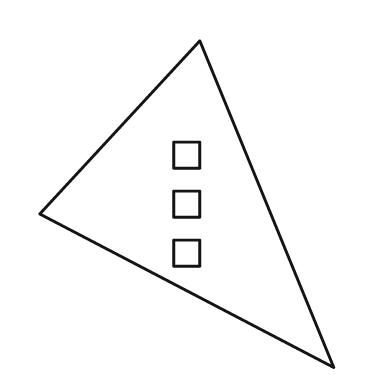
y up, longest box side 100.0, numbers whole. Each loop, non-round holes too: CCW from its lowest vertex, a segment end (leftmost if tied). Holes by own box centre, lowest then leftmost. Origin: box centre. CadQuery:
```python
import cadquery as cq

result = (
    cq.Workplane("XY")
    .moveTo(45.0, -50.0)
    .lineTo(4.0, 50.0)
    .lineTo(-45.0, -3.0)
    .close()
    .moveTo(-4.0, -19.0)
    .lineTo(4.0, -19.0)
    .lineTo(4.0, -11.0)
    .lineTo(-4.0, -11.0)
    .close()
    .moveTo(-4.0, -4.0)
    .lineTo(4.0, -4.0)
    .lineTo(4.0, 4.0)
    .lineTo(-4.0, 4.0)
    .close()
    .moveTo(-4.0, 11.0)
    .lineTo(4.0, 11.0)
    .lineTo(4.0, 19.0)
    .lineTo(-4.0, 19.0)
    .close()
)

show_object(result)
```